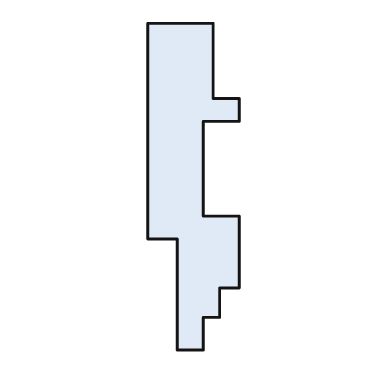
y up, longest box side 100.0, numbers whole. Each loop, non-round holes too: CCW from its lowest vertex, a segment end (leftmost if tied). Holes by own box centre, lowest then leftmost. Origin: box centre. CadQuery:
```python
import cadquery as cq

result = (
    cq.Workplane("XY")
    .moveTo(-5.0, -50.0)
    .lineTo(3.0, -50.0)
    .lineTo(3.0, -40.0)
    .lineTo(8.0, -40.0)
    .lineTo(8.0, -31.0)
    .lineTo(14.0, -31.0)
    .lineTo(14.0, -9.0)
    .lineTo(3.0, -9.0)
    .lineTo(3.0, 20.0)
    .lineTo(14.0, 20.0)
    .lineTo(14.0, 27.0)
    .lineTo(6.0, 27.0)
    .lineTo(6.0, 50.0)
    .lineTo(-14.0, 50.0)
    .lineTo(-14.0, -16.0)
    .lineTo(-5.0, -16.0)
    .close()
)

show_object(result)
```